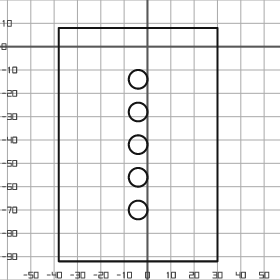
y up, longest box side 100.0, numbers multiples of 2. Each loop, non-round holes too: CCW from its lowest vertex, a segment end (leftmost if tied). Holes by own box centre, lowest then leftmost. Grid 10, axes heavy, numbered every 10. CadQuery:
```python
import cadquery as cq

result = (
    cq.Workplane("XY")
    .moveTo(-38.0, -92.0)
    .lineTo(30.0, -92.0)
    .lineTo(30.0, 8.0)
    .lineTo(-38.0, 8.0)
    .close()
    .moveTo(-4.0, -70.0)
    .circle(4.0)
    .moveTo(-4.0, -56.0)
    .circle(4.0)
    .moveTo(-4.0, -42.0)
    .circle(4.0)
    .moveTo(-4.0, -28.0)
    .circle(4.0)
    .moveTo(-4.0, -14.0)
    .circle(4.0)
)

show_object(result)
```